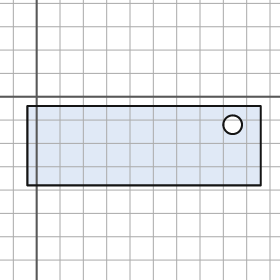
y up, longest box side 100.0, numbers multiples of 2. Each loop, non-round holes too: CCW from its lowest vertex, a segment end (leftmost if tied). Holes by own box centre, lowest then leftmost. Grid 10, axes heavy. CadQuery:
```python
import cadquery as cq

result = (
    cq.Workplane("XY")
    .moveTo(-4.0, -38.0)
    .lineTo(96.0, -38.0)
    .lineTo(96.0, -4.0)
    .lineTo(-4.0, -4.0)
    .close()
    .moveTo(84.0, -12.0)
    .circle(4.0)
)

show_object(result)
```